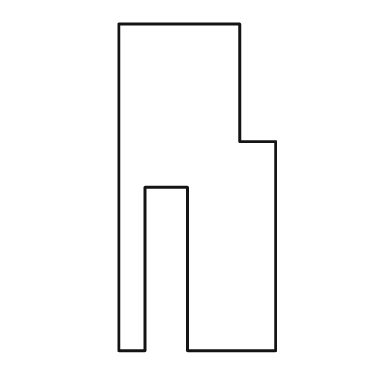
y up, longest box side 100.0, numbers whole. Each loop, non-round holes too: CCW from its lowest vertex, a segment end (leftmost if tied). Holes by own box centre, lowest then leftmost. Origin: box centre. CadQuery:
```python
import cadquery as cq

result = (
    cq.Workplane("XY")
    .moveTo(-24.0, -50.0)
    .lineTo(-16.0, -50.0)
    .lineTo(-16.0, 0.0)
    .lineTo(-3.0, 0.0)
    .lineTo(-3.0, -50.0)
    .lineTo(24.0, -50.0)
    .lineTo(24.0, 14.0)
    .lineTo(13.0, 14.0)
    .lineTo(13.0, 50.0)
    .lineTo(-24.0, 50.0)
    .close()
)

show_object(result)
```